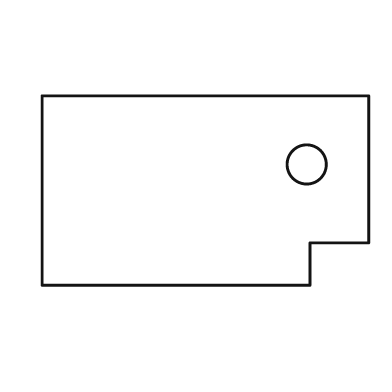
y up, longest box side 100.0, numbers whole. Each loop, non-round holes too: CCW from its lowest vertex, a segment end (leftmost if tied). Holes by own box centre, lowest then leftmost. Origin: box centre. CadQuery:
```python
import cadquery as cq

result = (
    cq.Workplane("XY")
    .moveTo(-50.0, -29.0)
    .lineTo(32.0, -29.0)
    .lineTo(32.0, -16.0)
    .lineTo(50.0, -16.0)
    .lineTo(50.0, 29.0)
    .lineTo(-50.0, 29.0)
    .close()
    .moveTo(31.0, 8.0)
    .circle(6.0)
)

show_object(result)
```